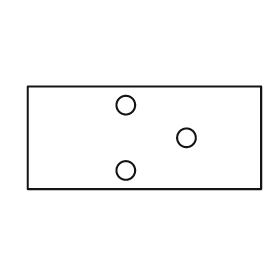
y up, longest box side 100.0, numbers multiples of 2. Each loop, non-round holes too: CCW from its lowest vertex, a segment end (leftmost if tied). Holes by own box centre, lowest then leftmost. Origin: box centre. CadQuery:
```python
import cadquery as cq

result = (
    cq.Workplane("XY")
    .moveTo(-50.0, -22.0)
    .lineTo(50.0, -22.0)
    .lineTo(50.0, 22.0)
    .lineTo(-50.0, 22.0)
    .close()
    .moveTo(-8.0, -14.0)
    .circle(4.0)
    .moveTo(18.0, 0.0)
    .circle(4.0)
    .moveTo(-8.0, 14.0)
    .circle(4.0)
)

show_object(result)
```